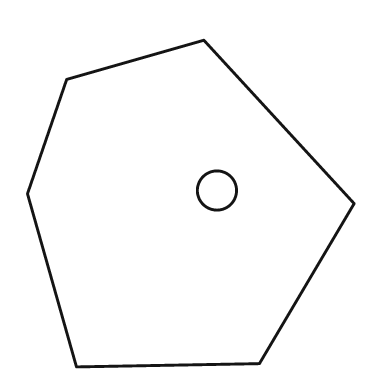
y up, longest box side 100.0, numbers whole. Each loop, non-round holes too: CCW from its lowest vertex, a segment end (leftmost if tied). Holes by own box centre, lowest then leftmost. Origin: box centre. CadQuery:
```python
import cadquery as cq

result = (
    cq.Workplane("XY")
    .moveTo(-35.0, -50.0)
    .lineTo(21.0, -49.0)
    .lineTo(50.0, 0.0)
    .lineTo(4.0, 50.0)
    .lineTo(-38.0, 38.0)
    .lineTo(-50.0, 3.0)
    .close()
    .moveTo(8.0, 4.0)
    .circle(6.0)
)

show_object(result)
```